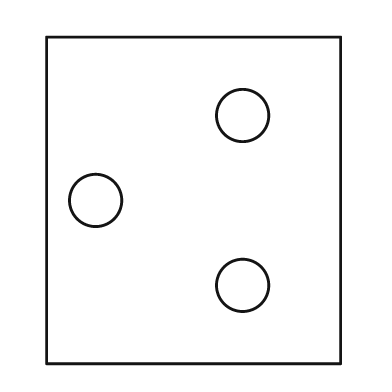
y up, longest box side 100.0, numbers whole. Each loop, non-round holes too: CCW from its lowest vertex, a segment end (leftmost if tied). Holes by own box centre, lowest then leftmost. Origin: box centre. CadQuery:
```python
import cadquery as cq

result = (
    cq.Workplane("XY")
    .moveTo(-45.0, -50.0)
    .lineTo(45.0, -50.0)
    .lineTo(45.0, 50.0)
    .lineTo(-45.0, 50.0)
    .close()
    .moveTo(15.0, -26.0)
    .circle(8.0)
    .moveTo(-30.0, 0.0)
    .circle(8.0)
    .moveTo(15.0, 26.0)
    .circle(8.0)
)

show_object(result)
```